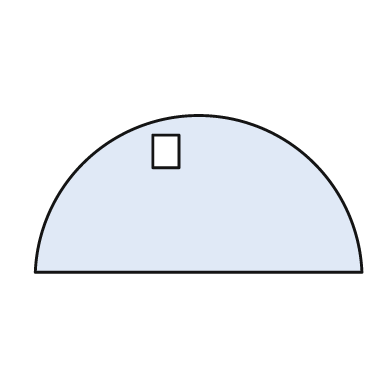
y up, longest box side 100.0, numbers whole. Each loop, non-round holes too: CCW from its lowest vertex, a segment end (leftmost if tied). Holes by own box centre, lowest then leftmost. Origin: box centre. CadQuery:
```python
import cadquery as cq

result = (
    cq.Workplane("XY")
    .moveTo(-50.0, -24.0)
    .lineTo(50.0, -24.0)
    .threePointArc((0.0, 24.0), (-50.0, -24.0))
    .close()
    .moveTo(-14.0, 8.0)
    .lineTo(-6.0, 8.0)
    .lineTo(-6.0, 18.0)
    .lineTo(-14.0, 18.0)
    .close()
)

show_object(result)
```